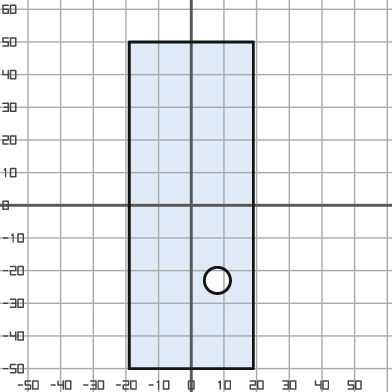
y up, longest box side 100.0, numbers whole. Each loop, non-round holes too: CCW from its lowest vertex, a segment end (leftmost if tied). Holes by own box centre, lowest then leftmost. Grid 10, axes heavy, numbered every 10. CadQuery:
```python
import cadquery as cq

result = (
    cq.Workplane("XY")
    .moveTo(-19.0, -50.0)
    .lineTo(19.0, -50.0)
    .lineTo(19.0, 50.0)
    .lineTo(-19.0, 50.0)
    .close()
    .moveTo(8.0, -23.0)
    .circle(4.0)
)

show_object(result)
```